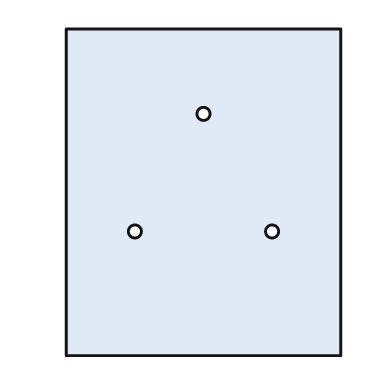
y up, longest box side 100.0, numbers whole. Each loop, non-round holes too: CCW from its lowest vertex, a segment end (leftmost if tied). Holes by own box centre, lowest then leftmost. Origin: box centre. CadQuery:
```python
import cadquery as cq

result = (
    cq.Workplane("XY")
    .moveTo(-42.0, -50.0)
    .lineTo(42.0, -50.0)
    .lineTo(42.0, 50.0)
    .lineTo(-42.0, 50.0)
    .close()
    .moveTo(-21.0, -12.0)
    .circle(2.0)
    .moveTo(21.0, -12.0)
    .circle(2.0)
    .moveTo(0.0, 24.0)
    .circle(2.0)
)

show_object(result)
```